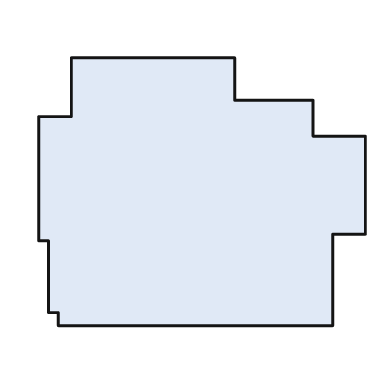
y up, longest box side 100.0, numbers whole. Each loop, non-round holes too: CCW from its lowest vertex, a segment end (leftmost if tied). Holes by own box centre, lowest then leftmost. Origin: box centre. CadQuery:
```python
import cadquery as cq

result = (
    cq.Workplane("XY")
    .moveTo(-44.0, -41.0)
    .lineTo(40.0, -41.0)
    .lineTo(40.0, -13.0)
    .lineTo(50.0, -13.0)
    .lineTo(50.0, 17.0)
    .lineTo(34.0, 17.0)
    .lineTo(34.0, 28.0)
    .lineTo(10.0, 28.0)
    .lineTo(10.0, 41.0)
    .lineTo(-40.0, 41.0)
    .lineTo(-40.0, 23.0)
    .lineTo(-50.0, 23.0)
    .lineTo(-50.0, -15.0)
    .lineTo(-47.0, -15.0)
    .lineTo(-47.0, -37.0)
    .lineTo(-44.0, -37.0)
    .close()
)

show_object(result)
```